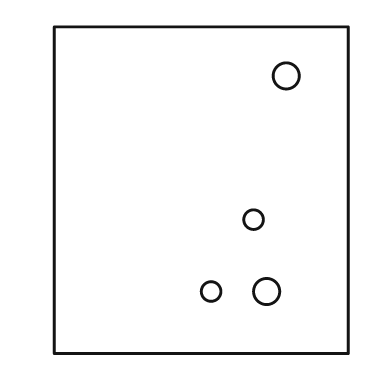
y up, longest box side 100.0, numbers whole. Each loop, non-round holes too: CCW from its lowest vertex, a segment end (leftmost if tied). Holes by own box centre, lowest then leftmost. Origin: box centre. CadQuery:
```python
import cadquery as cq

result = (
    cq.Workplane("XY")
    .moveTo(-45.0, -50.0)
    .lineTo(45.0, -50.0)
    .lineTo(45.0, 50.0)
    .lineTo(-45.0, 50.0)
    .close()
    .moveTo(3.0, -31.0)
    .circle(3.0)
    .moveTo(20.0, -31.0)
    .circle(4.0)
    .moveTo(16.0, -9.0)
    .circle(3.0)
    .moveTo(26.0, 35.0)
    .circle(4.0)
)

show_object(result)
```